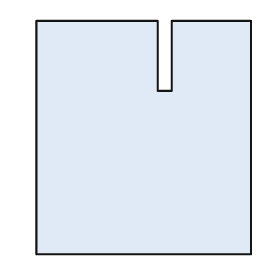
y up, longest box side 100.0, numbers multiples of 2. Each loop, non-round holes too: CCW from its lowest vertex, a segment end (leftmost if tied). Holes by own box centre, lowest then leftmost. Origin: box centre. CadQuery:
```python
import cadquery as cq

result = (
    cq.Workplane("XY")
    .moveTo(-46.0, -50.0)
    .lineTo(46.0, -50.0)
    .lineTo(46.0, 50.0)
    .lineTo(12.0, 50.0)
    .lineTo(12.0, 20.0)
    .lineTo(6.0, 20.0)
    .lineTo(6.0, 50.0)
    .lineTo(-46.0, 50.0)
    .close()
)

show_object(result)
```